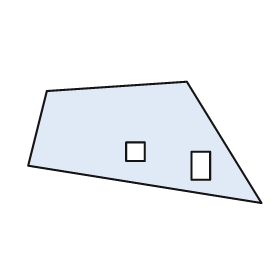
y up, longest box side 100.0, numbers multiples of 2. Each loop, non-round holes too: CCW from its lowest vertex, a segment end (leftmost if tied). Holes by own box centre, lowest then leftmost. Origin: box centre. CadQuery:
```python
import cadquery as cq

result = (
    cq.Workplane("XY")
    .moveTo(50.0, -26.0)
    .lineTo(18.0, 26.0)
    .lineTo(-42.0, 22.0)
    .lineTo(-50.0, -10.0)
    .close()
    .moveTo(20.0, -16.0)
    .lineTo(28.0, -16.0)
    .lineTo(28.0, -4.0)
    .lineTo(20.0, -4.0)
    .close()
    .moveTo(-8.0, -8.0)
    .lineTo(0.0, -8.0)
    .lineTo(0.0, 0.0)
    .lineTo(-8.0, 0.0)
    .close()
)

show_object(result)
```